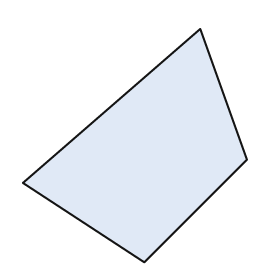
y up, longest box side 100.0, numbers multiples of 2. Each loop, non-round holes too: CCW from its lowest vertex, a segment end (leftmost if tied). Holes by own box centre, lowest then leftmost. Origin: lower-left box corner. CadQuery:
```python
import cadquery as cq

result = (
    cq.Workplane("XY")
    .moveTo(52.0, 0.0)
    .lineTo(96.0, 44.0)
    .lineTo(76.0, 100.0)
    .lineTo(0.0, 34.0)
    .close()
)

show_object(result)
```